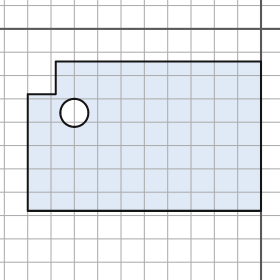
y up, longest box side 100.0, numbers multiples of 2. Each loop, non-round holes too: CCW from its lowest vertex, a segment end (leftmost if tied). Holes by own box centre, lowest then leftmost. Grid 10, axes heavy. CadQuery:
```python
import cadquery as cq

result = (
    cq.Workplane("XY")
    .moveTo(-100.0, -78.0)
    .lineTo(0.0, -78.0)
    .lineTo(0.0, -14.0)
    .lineTo(-88.0, -14.0)
    .lineTo(-88.0, -28.0)
    .lineTo(-100.0, -28.0)
    .close()
    .moveTo(-80.0, -36.0)
    .circle(6.0)
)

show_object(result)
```